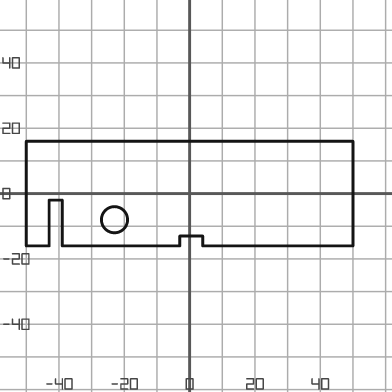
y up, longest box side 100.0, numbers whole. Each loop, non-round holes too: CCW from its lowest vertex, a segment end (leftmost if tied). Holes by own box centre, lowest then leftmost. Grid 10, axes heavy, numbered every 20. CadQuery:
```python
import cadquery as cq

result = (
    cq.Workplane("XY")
    .moveTo(-50.0, -16.0)
    .lineTo(-43.0, -16.0)
    .lineTo(-43.0, -2.0)
    .lineTo(-39.0, -2.0)
    .lineTo(-39.0, -16.0)
    .lineTo(-3.0, -16.0)
    .lineTo(-3.0, -13.0)
    .lineTo(4.0, -13.0)
    .lineTo(4.0, -16.0)
    .lineTo(50.0, -16.0)
    .lineTo(50.0, 16.0)
    .lineTo(-50.0, 16.0)
    .close()
    .moveTo(-23.0, -8.0)
    .circle(4.0)
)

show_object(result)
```